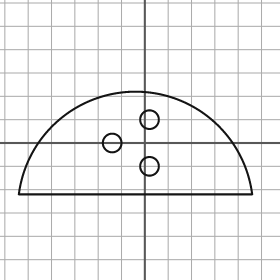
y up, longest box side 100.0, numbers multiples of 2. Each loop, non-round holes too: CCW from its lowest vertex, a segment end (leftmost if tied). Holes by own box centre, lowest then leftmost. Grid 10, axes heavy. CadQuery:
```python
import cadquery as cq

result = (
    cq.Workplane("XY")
    .moveTo(-54.0, -22.0)
    .lineTo(46.0, -22.0)
    .threePointArc((-4.0, 22.0), (-54.0, -22.0))
    .close()
    .moveTo(2.0, -10.0)
    .circle(4.0)
    .moveTo(-14.0, 0.0)
    .circle(4.0)
    .moveTo(2.0, 10.0)
    .circle(4.0)
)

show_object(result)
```